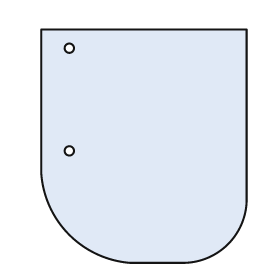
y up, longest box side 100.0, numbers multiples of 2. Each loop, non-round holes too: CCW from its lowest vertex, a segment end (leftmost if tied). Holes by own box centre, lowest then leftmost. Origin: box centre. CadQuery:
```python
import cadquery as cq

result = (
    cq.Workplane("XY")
    .moveTo(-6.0, -50.0)
    .lineTo(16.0, -50.0)
    .threePointArc((36.0, -42.0), (44.0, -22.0))
    .lineTo(44.0, 50.0)
    .lineTo(-44.0, 50.0)
    .lineTo(-44.0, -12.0)
    .threePointArc((-32.0, -38.0), (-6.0, -50.0))
    .close()
    .moveTo(-32.0, -2.0)
    .circle(2.0)
    .moveTo(-32.0, 42.0)
    .circle(2.0)
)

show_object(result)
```